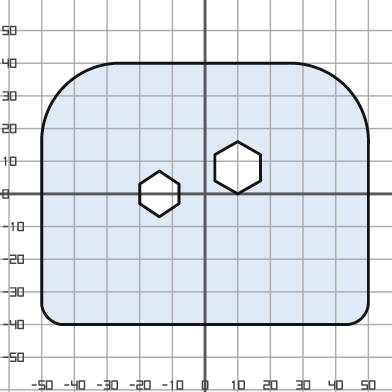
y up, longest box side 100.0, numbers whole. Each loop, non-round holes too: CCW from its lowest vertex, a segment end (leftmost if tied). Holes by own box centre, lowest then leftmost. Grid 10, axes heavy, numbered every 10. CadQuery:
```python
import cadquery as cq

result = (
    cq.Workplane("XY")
    .moveTo(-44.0, -40.0)
    .lineTo(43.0, -40.0)
    .threePointArc((48.0, -38.0), (50.0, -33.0))
    .lineTo(50.0, 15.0)
    .threePointArc((43.0, 33.0), (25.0, 40.0))
    .lineTo(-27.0, 40.0)
    .threePointArc((-43.0, 33.0), (-50.0, 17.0))
    .lineTo(-50.0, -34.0)
    .threePointArc((-48.0, -38.0), (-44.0, -40.0))
    .close()
    .moveTo(-14.0, -7.0)
    .lineTo(-8.0, -3.0)
    .lineTo(-8.0, 3.0)
    .lineTo(-14.0, 7.0)
    .lineTo(-20.0, 3.0)
    .lineTo(-20.0, -3.0)
    .close()
    .moveTo(10.0, 0.0)
    .lineTo(17.0, 4.0)
    .lineTo(17.0, 12.0)
    .lineTo(10.0, 16.0)
    .lineTo(3.0, 12.0)
    .lineTo(3.0, 4.0)
    .close()
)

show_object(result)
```